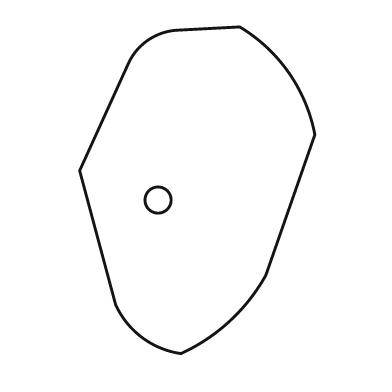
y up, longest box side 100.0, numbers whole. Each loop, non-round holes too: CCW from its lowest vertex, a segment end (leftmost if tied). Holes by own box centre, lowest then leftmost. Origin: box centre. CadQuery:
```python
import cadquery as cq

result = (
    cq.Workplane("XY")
    .moveTo(-5.0, -50.0)
    .threePointArc((10.0, -40.0), (21.0, -26.0))
    .lineTo(36.0, 17.0)
    .threePointArc((28.0, 36.0), (13.0, 50.0))
    .lineTo(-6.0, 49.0)
    .threePointArc((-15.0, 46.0), (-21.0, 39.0))
    .lineTo(-36.0, 6.0)
    .lineTo(-25.0, -35.0)
    .threePointArc((-17.0, -45.0), (-5.0, -50.0))
    .close()
    .moveTo(-12.0, -3.0)
    .circle(4.0)
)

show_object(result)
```